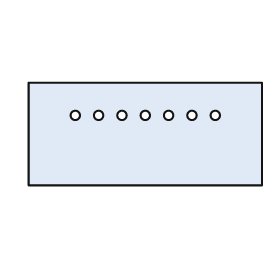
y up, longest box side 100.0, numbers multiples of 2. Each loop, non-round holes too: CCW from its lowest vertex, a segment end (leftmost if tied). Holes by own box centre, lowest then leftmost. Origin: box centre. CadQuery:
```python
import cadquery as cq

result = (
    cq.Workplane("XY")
    .moveTo(-50.0, -22.0)
    .lineTo(50.0, -22.0)
    .lineTo(50.0, 22.0)
    .lineTo(-50.0, 22.0)
    .close()
    .moveTo(-30.0, 8.0)
    .circle(2.0)
    .moveTo(-20.0, 8.0)
    .circle(2.0)
    .moveTo(-10.0, 8.0)
    .circle(2.0)
    .moveTo(0.0, 8.0)
    .circle(2.0)
    .moveTo(10.0, 8.0)
    .circle(2.0)
    .moveTo(20.0, 8.0)
    .circle(2.0)
    .moveTo(30.0, 8.0)
    .circle(2.0)
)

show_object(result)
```